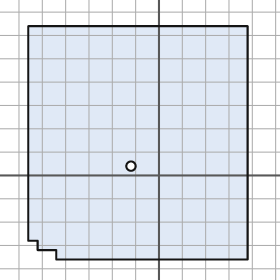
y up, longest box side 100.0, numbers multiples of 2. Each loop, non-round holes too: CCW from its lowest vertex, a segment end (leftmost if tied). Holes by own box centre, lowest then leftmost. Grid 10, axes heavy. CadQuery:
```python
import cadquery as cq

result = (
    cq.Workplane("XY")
    .moveTo(-44.0, -36.0)
    .lineTo(38.0, -36.0)
    .lineTo(38.0, 64.0)
    .lineTo(-56.0, 64.0)
    .lineTo(-56.0, -28.0)
    .lineTo(-52.0, -28.0)
    .lineTo(-52.0, -32.0)
    .lineTo(-44.0, -32.0)
    .close()
    .moveTo(-12.0, 4.0)
    .circle(2.0)
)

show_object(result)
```